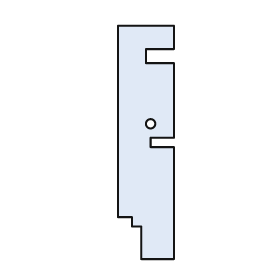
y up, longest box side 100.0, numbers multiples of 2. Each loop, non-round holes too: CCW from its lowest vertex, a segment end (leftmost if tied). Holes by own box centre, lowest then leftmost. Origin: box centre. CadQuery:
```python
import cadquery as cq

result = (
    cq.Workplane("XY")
    .moveTo(-2.0, -50.0)
    .lineTo(12.0, -50.0)
    .lineTo(12.0, -2.0)
    .lineTo(2.0, -2.0)
    .lineTo(2.0, 2.0)
    .lineTo(12.0, 2.0)
    .lineTo(12.0, 34.0)
    .lineTo(0.0, 34.0)
    .lineTo(0.0, 40.0)
    .lineTo(12.0, 40.0)
    .lineTo(12.0, 50.0)
    .lineTo(-12.0, 50.0)
    .lineTo(-12.0, -32.0)
    .lineTo(-6.0, -32.0)
    .lineTo(-6.0, -36.0)
    .lineTo(-2.0, -36.0)
    .close()
    .moveTo(2.0, 8.0)
    .circle(2.0)
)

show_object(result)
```